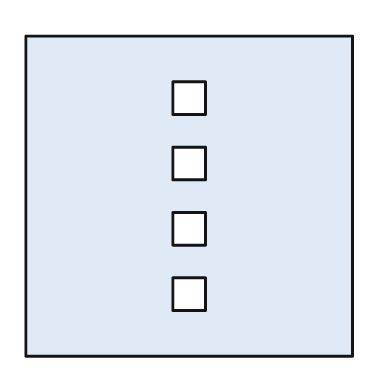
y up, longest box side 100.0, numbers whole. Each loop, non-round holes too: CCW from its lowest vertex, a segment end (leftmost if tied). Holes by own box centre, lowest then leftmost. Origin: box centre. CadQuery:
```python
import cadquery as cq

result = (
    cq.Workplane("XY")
    .moveTo(-50.0, -49.0)
    .lineTo(50.0, -49.0)
    .lineTo(50.0, 49.0)
    .lineTo(-50.0, 49.0)
    .close()
    .moveTo(-5.0, -35.0)
    .lineTo(5.0, -35.0)
    .lineTo(5.0, -25.0)
    .lineTo(-5.0, -25.0)
    .close()
    .moveTo(-5.0, -15.0)
    .lineTo(5.0, -15.0)
    .lineTo(5.0, -5.0)
    .lineTo(-5.0, -5.0)
    .close()
    .moveTo(-5.0, 5.0)
    .lineTo(5.0, 5.0)
    .lineTo(5.0, 15.0)
    .lineTo(-5.0, 15.0)
    .close()
    .moveTo(-5.0, 25.0)
    .lineTo(5.0, 25.0)
    .lineTo(5.0, 35.0)
    .lineTo(-5.0, 35.0)
    .close()
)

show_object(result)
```